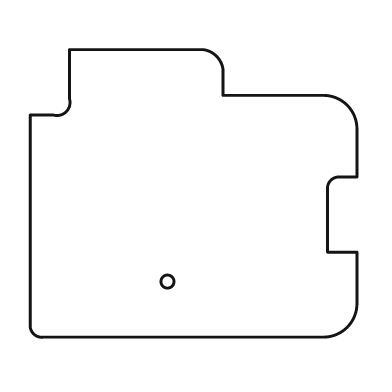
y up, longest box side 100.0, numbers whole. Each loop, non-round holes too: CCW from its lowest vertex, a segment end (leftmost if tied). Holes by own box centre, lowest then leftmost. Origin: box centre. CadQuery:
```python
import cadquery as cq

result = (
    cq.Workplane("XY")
    .moveTo(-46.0, -44.0)
    .lineTo(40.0, -44.0)
    .threePointArc((47.0, -41.0), (50.0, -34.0))
    .lineTo(50.0, -18.0)
    .lineTo(41.0, -18.0)
    .lineTo(41.0, 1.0)
    .threePointArc((42.0, 4.0), (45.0, 5.0))
    .lineTo(50.0, 5.0)
    .lineTo(50.0, 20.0)
    .threePointArc((47.0, 27.0), (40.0, 30.0))
    .lineTo(9.0, 30.0)
    .lineTo(9.0, 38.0)
    .threePointArc((7.0, 42.0), (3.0, 44.0))
    .lineTo(-38.0, 44.0)
    .lineTo(-38.0, 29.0)
    .threePointArc((-39.0, 25.0), (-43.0, 24.0))
    .lineTo(-50.0, 24.0)
    .lineTo(-50.0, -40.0)
    .threePointArc((-49.0, -43.0), (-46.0, -44.0))
    .close()
    .moveTo(-8.0, -27.0)
    .circle(2.0)
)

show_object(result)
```